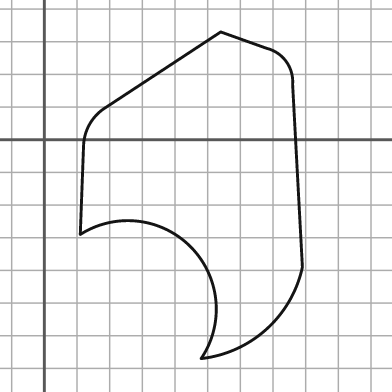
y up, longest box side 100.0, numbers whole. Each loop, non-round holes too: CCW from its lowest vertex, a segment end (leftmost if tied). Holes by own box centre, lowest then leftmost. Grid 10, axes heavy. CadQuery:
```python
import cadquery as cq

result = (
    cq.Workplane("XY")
    .moveTo(48.0, -67.0)
    .threePointArc((68.0, -58.0), (79.0, -39.0))
    .lineTo(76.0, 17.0)
    .threePointArc((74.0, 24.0), (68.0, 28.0))
    .lineTo(54.0, 33.0)
    .lineTo(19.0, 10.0)
    .threePointArc((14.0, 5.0), (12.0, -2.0))
    .lineTo(11.0, -29.0)
    .threePointArc((45.0, -33.0), (48.0, -67.0))
    .close()
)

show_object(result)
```